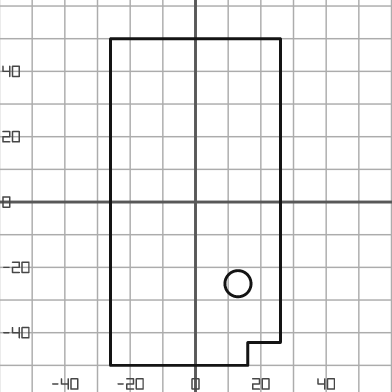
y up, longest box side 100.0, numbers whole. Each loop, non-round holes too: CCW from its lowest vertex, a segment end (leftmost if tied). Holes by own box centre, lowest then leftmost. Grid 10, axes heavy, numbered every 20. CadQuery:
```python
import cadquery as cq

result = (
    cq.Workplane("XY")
    .moveTo(-26.0, -50.0)
    .lineTo(16.0, -50.0)
    .lineTo(16.0, -43.0)
    .lineTo(26.0, -43.0)
    .lineTo(26.0, 50.0)
    .lineTo(-26.0, 50.0)
    .close()
    .moveTo(13.0, -25.0)
    .circle(4.0)
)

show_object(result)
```